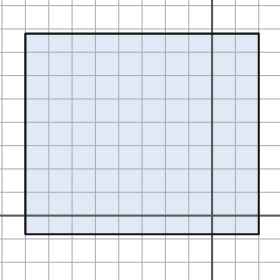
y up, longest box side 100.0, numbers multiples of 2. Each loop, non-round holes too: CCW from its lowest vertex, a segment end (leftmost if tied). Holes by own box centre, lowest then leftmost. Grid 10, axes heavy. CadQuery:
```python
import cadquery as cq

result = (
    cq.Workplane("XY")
    .moveTo(-80.0, -8.0)
    .lineTo(20.0, -8.0)
    .lineTo(20.0, 78.0)
    .lineTo(-80.0, 78.0)
    .close()
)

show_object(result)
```